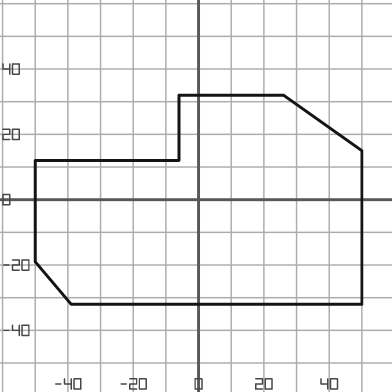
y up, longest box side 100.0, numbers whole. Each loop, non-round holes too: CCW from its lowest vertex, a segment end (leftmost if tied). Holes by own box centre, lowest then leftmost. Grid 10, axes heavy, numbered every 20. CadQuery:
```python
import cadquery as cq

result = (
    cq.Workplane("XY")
    .moveTo(-39.0, -32.0)
    .lineTo(50.0, -32.0)
    .lineTo(50.0, 15.0)
    .lineTo(26.0, 32.0)
    .lineTo(-6.0, 32.0)
    .lineTo(-6.0, 12.0)
    .lineTo(-50.0, 12.0)
    .lineTo(-50.0, -19.0)
    .close()
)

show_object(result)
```